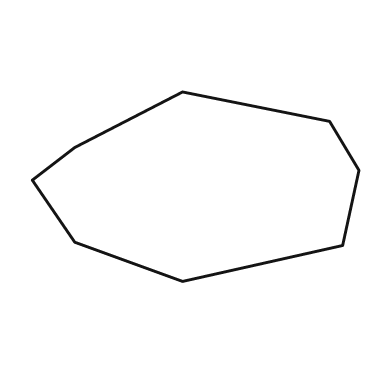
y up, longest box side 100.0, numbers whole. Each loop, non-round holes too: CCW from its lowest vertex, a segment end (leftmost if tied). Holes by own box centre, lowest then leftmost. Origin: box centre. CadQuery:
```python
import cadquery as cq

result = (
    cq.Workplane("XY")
    .moveTo(-4.0, -29.0)
    .lineTo(45.0, -18.0)
    .lineTo(50.0, 5.0)
    .lineTo(41.0, 20.0)
    .lineTo(-4.0, 29.0)
    .lineTo(-37.0, 12.0)
    .lineTo(-50.0, 2.0)
    .lineTo(-37.0, -17.0)
    .close()
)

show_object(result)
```